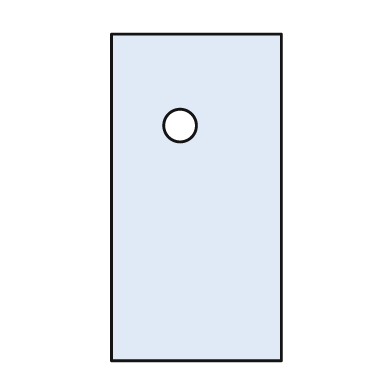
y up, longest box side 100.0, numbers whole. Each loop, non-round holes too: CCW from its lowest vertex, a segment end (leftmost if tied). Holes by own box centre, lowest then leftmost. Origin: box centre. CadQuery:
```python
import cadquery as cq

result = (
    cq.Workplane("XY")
    .moveTo(-26.0, -50.0)
    .lineTo(26.0, -50.0)
    .lineTo(26.0, 50.0)
    .lineTo(-26.0, 50.0)
    .close()
    .moveTo(-5.0, 22.0)
    .circle(5.0)
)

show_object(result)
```